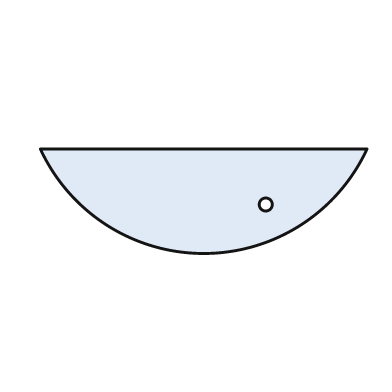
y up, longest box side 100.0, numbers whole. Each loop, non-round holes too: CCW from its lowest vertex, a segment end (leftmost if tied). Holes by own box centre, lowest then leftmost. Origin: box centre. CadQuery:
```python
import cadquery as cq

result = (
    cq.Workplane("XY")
    .moveTo(-50.0, 16.0)
    .threePointArc((0.0, -16.0), (50.0, 16.0))
    .close()
    .moveTo(19.0, -1.0)
    .circle(2.0)
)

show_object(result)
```